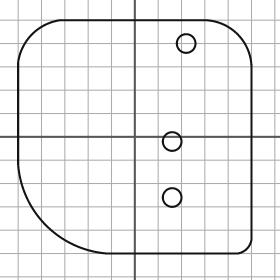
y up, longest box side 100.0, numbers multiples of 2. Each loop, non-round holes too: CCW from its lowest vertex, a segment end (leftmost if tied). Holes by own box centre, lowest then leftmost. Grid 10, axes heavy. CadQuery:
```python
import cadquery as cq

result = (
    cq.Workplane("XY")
    .moveTo(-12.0, -50.0)
    .lineTo(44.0, -50.0)
    .threePointArc((48.0, -48.0), (50.0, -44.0))
    .lineTo(50.0, 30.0)
    .threePointArc((44.0, 44.0), (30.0, 50.0))
    .lineTo(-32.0, 50.0)
    .threePointArc((-44.0, 44.0), (-50.0, 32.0))
    .lineTo(-50.0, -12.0)
    .threePointArc((-38.0, -38.0), (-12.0, -50.0))
    .close()
    .moveTo(16.0, -26.0)
    .circle(4.0)
    .moveTo(16.0, -2.0)
    .circle(4.0)
    .moveTo(22.0, 40.0)
    .circle(4.0)
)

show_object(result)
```